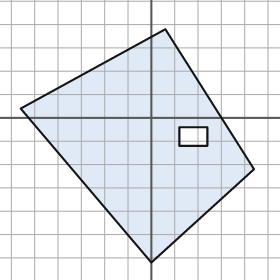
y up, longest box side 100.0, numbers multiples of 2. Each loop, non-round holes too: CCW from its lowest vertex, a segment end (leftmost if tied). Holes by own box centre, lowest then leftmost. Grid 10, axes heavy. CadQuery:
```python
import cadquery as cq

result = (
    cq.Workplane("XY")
    .moveTo(0.0, -62.0)
    .lineTo(44.0, -22.0)
    .lineTo(6.0, 38.0)
    .lineTo(-56.0, 4.0)
    .close()
    .moveTo(12.0, -12.0)
    .lineTo(24.0, -12.0)
    .lineTo(24.0, -4.0)
    .lineTo(12.0, -4.0)
    .close()
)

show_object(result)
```